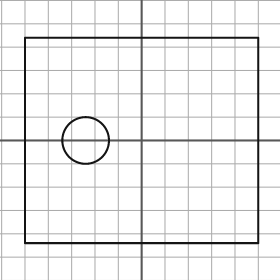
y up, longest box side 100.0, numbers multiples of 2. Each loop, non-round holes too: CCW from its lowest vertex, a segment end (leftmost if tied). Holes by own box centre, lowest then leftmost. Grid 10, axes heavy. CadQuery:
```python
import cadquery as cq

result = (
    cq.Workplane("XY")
    .moveTo(-50.0, -44.0)
    .lineTo(50.0, -44.0)
    .lineTo(50.0, 44.0)
    .lineTo(-50.0, 44.0)
    .close()
    .moveTo(-24.0, 0.0)
    .circle(10.0)
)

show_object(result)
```